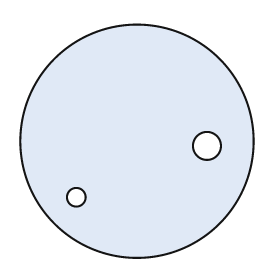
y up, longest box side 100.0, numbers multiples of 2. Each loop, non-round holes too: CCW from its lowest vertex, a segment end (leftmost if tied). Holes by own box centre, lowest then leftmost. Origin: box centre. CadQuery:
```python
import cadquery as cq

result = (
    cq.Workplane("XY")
    .moveTo(0.0, 0.0)
    .circle(50.0)
    .moveTo(-26.0, -24.0)
    .circle(4.0)
    .moveTo(30.0, -2.0)
    .circle(6.0)
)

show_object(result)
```